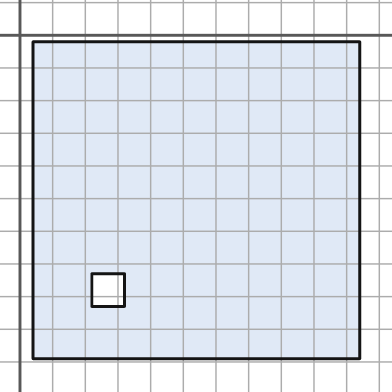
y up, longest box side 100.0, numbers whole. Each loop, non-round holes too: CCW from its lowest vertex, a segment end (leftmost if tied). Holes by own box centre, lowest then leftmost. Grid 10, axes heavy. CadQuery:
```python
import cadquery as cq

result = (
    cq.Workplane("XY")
    .moveTo(4.0, -99.0)
    .lineTo(104.0, -99.0)
    .lineTo(104.0, -2.0)
    .lineTo(4.0, -2.0)
    .close()
    .moveTo(22.0, -83.0)
    .lineTo(32.0, -83.0)
    .lineTo(32.0, -73.0)
    .lineTo(22.0, -73.0)
    .close()
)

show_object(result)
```